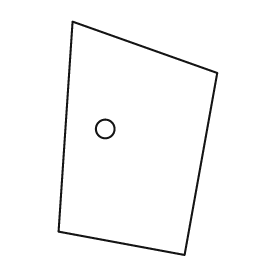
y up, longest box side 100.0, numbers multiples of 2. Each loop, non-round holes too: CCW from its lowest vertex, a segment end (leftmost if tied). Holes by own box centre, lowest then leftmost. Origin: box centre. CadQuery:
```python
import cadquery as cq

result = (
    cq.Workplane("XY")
    .moveTo(20.0, -50.0)
    .lineTo(34.0, 28.0)
    .lineTo(-28.0, 50.0)
    .lineTo(-34.0, -40.0)
    .close()
    .moveTo(-14.0, 4.0)
    .circle(4.0)
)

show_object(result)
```